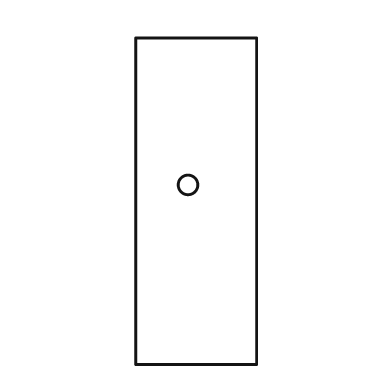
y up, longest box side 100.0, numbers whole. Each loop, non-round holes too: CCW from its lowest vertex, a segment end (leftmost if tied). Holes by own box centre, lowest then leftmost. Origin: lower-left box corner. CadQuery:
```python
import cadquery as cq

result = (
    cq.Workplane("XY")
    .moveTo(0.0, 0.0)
    .lineTo(37.0, 0.0)
    .lineTo(37.0, 100.0)
    .lineTo(0.0, 100.0)
    .close()
    .moveTo(16.0, 55.0)
    .circle(3.0)
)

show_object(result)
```